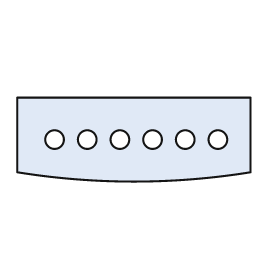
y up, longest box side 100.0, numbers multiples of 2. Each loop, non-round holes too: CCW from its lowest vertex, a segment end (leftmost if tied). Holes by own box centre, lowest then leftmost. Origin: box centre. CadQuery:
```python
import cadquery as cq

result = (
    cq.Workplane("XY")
    .moveTo(-50.0, -14.0)
    .threePointArc((0.0, -18.0), (50.0, -14.0))
    .lineTo(50.0, 18.0)
    .lineTo(-50.0, 18.0)
    .close()
    .moveTo(-34.0, 0.0)
    .circle(4.0)
    .moveTo(-20.0, 0.0)
    .circle(4.0)
    .moveTo(-6.0, 0.0)
    .circle(4.0)
    .moveTo(8.0, 0.0)
    .circle(4.0)
    .moveTo(22.0, 0.0)
    .circle(4.0)
    .moveTo(36.0, 0.0)
    .circle(4.0)
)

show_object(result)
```